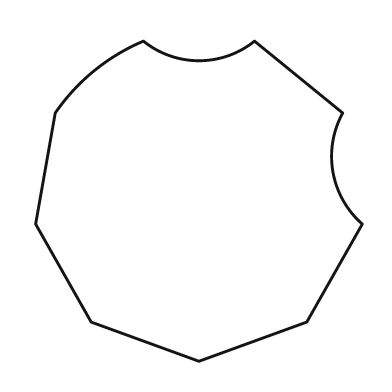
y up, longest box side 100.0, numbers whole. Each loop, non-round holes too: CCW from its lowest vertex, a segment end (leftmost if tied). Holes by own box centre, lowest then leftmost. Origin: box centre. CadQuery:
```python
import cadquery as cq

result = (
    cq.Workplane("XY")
    .moveTo(0.0, -49.0)
    .lineTo(33.0, -37.0)
    .lineTo(50.0, -7.0)
    .threePointArc((41.0, 9.0), (44.0, 27.0))
    .lineTo(17.0, 49.0)
    .threePointArc((0.0, 43.0), (-17.0, 49.0))
    .threePointArc((-32.0, 40.0), (-44.0, 27.0))
    .lineTo(-50.0, -7.0)
    .lineTo(-33.0, -37.0)
    .close()
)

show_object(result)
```